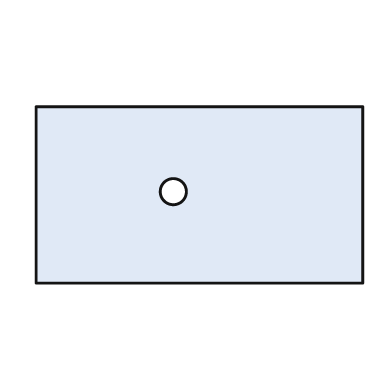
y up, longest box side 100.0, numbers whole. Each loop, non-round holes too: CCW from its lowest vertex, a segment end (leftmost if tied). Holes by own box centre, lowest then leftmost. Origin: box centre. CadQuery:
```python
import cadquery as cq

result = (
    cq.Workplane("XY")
    .moveTo(-50.0, -27.0)
    .lineTo(50.0, -27.0)
    .lineTo(50.0, 27.0)
    .lineTo(-50.0, 27.0)
    .close()
    .moveTo(-8.0, 1.0)
    .circle(4.0)
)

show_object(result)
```